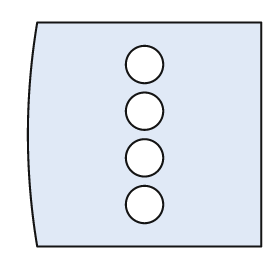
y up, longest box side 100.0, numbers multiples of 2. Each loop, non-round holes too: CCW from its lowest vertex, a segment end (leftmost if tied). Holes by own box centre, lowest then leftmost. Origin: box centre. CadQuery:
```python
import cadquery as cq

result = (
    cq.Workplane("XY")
    .moveTo(-46.0, -48.0)
    .lineTo(50.0, -48.0)
    .lineTo(50.0, 48.0)
    .lineTo(-46.0, 48.0)
    .threePointArc((-50.0, 0.0), (-46.0, -48.0))
    .close()
    .moveTo(0.0, -30.0)
    .circle(8.0)
    .moveTo(0.0, -10.0)
    .circle(8.0)
    .moveTo(0.0, 10.0)
    .circle(8.0)
    .moveTo(0.0, 30.0)
    .circle(8.0)
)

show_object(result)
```